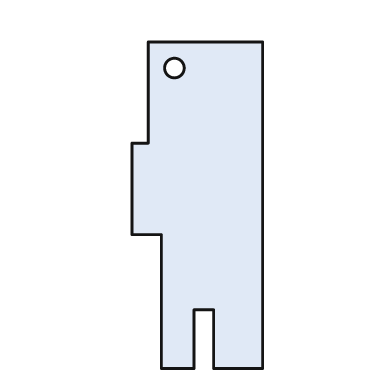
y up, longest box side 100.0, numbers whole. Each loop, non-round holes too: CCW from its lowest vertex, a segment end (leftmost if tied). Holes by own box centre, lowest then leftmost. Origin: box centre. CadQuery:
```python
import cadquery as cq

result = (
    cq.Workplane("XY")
    .moveTo(-11.0, -50.0)
    .lineTo(-1.0, -50.0)
    .lineTo(-1.0, -32.0)
    .lineTo(5.0, -32.0)
    .lineTo(5.0, -50.0)
    .lineTo(20.0, -50.0)
    .lineTo(20.0, 50.0)
    .lineTo(-15.0, 50.0)
    .lineTo(-15.0, 19.0)
    .lineTo(-20.0, 19.0)
    .lineTo(-20.0, -9.0)
    .lineTo(-11.0, -9.0)
    .close()
    .moveTo(-7.0, 42.0)
    .circle(3.0)
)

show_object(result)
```